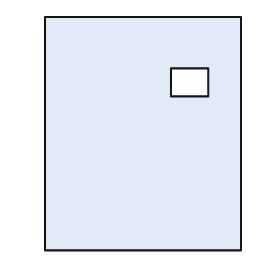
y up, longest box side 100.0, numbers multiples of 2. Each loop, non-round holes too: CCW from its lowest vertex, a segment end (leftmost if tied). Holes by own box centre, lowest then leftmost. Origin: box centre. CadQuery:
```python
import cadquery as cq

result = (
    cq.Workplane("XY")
    .moveTo(-42.0, -50.0)
    .lineTo(42.0, -50.0)
    .lineTo(42.0, 50.0)
    .lineTo(-42.0, 50.0)
    .close()
    .moveTo(12.0, 16.0)
    .lineTo(28.0, 16.0)
    .lineTo(28.0, 28.0)
    .lineTo(12.0, 28.0)
    .close()
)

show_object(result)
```